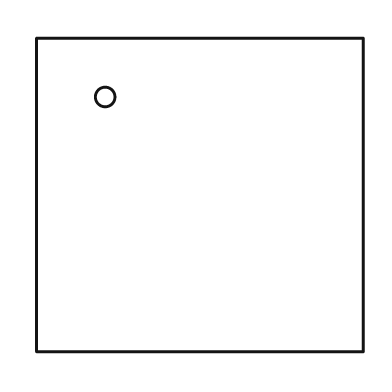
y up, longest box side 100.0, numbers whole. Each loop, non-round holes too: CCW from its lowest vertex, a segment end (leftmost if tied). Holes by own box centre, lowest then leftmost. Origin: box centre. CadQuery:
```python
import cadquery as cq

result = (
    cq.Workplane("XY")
    .moveTo(-50.0, -48.0)
    .lineTo(50.0, -48.0)
    .lineTo(50.0, 48.0)
    .lineTo(-50.0, 48.0)
    .close()
    .moveTo(-29.0, 30.0)
    .circle(3.0)
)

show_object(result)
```